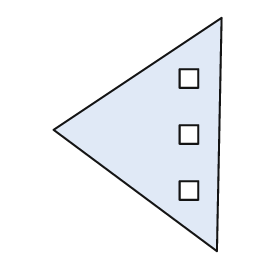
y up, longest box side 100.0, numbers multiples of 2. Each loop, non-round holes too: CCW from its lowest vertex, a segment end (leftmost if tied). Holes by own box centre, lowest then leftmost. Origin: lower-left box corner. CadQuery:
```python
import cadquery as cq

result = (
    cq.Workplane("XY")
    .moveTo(70.0, 0.0)
    .lineTo(72.0, 100.0)
    .lineTo(0.0, 52.0)
    .close()
    .moveTo(54.0, 22.0)
    .lineTo(62.0, 22.0)
    .lineTo(62.0, 30.0)
    .lineTo(54.0, 30.0)
    .close()
    .moveTo(54.0, 46.0)
    .lineTo(62.0, 46.0)
    .lineTo(62.0, 54.0)
    .lineTo(54.0, 54.0)
    .close()
    .moveTo(54.0, 70.0)
    .lineTo(62.0, 70.0)
    .lineTo(62.0, 78.0)
    .lineTo(54.0, 78.0)
    .close()
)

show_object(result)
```